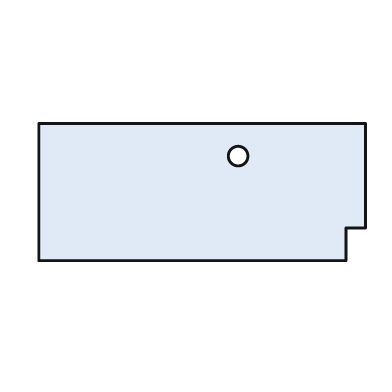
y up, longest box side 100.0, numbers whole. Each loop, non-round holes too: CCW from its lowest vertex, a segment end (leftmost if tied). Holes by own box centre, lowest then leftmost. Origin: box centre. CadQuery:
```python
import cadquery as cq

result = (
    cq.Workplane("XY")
    .moveTo(-50.0, -21.0)
    .lineTo(44.0, -21.0)
    .lineTo(44.0, -11.0)
    .lineTo(50.0, -11.0)
    .lineTo(50.0, 21.0)
    .lineTo(-50.0, 21.0)
    .close()
    .moveTo(11.0, 11.0)
    .circle(3.0)
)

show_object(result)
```